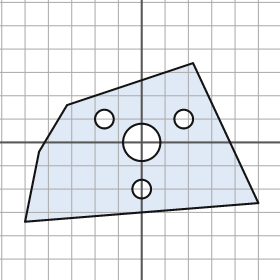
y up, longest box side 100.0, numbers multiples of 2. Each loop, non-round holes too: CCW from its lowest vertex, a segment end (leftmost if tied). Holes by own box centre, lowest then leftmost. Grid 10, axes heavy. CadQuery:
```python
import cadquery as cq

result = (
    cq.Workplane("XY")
    .moveTo(-50.0, -34.0)
    .lineTo(50.0, -26.0)
    .lineTo(22.0, 34.0)
    .lineTo(-32.0, 16.0)
    .lineTo(-44.0, -4.0)
    .close()
    .moveTo(0.0, -20.0)
    .circle(4.0)
    .moveTo(0.0, 0.0)
    .circle(8.0)
    .moveTo(-16.0, 10.0)
    .circle(4.0)
    .moveTo(18.0, 10.0)
    .circle(4.0)
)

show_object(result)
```